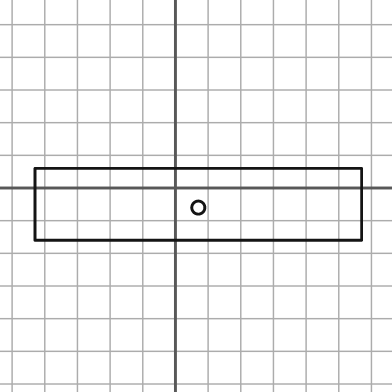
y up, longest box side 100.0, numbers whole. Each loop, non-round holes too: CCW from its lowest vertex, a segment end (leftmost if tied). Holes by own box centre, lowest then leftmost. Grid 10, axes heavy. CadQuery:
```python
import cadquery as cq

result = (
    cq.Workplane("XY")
    .moveTo(-43.0, -16.0)
    .lineTo(57.0, -16.0)
    .lineTo(57.0, 6.0)
    .lineTo(-43.0, 6.0)
    .close()
    .moveTo(7.0, -6.0)
    .circle(2.0)
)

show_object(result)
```